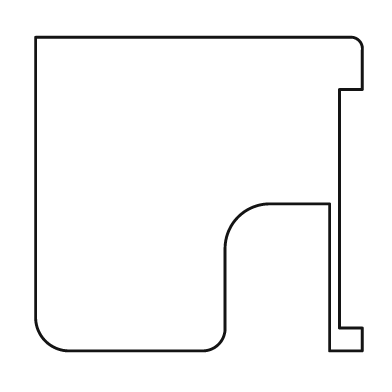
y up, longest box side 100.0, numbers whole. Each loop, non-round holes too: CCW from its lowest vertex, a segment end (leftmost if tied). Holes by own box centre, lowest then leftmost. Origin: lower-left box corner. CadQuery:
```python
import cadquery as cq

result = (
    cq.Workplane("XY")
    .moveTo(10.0, 0.0)
    .lineTo(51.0, 0.0)
    .threePointArc((56.0, 2.0), (58.0, 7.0))
    .lineTo(58.0, 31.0)
    .threePointArc((62.0, 41.0), (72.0, 45.0))
    .lineTo(90.0, 45.0)
    .lineTo(90.0, 0.0)
    .lineTo(100.0, 0.0)
    .lineTo(100.0, 7.0)
    .lineTo(93.0, 7.0)
    .lineTo(93.0, 80.0)
    .lineTo(100.0, 80.0)
    .lineTo(100.0, 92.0)
    .threePointArc((99.0, 95.0), (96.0, 96.0))
    .lineTo(0.0, 96.0)
    .lineTo(0.0, 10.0)
    .threePointArc((3.0, 3.0), (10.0, 0.0))
    .close()
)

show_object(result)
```